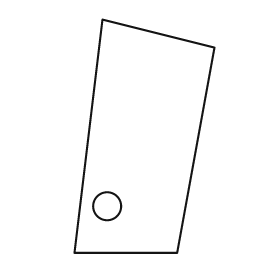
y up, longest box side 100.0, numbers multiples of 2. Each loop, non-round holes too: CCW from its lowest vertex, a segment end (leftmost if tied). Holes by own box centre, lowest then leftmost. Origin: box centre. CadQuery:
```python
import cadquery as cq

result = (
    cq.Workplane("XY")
    .moveTo(-30.0, -50.0)
    .lineTo(14.0, -50.0)
    .lineTo(30.0, 38.0)
    .lineTo(-18.0, 50.0)
    .close()
    .moveTo(-16.0, -30.0)
    .circle(6.0)
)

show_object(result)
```